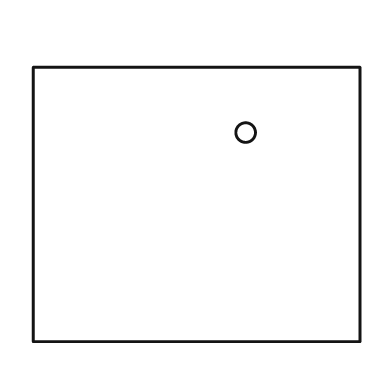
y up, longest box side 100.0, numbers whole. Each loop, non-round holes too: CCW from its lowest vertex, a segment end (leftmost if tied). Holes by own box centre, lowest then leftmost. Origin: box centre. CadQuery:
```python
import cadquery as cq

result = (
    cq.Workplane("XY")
    .moveTo(-50.0, -42.0)
    .lineTo(50.0, -42.0)
    .lineTo(50.0, 42.0)
    .lineTo(-50.0, 42.0)
    .close()
    .moveTo(15.0, 22.0)
    .circle(3.0)
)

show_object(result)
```